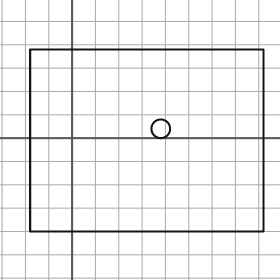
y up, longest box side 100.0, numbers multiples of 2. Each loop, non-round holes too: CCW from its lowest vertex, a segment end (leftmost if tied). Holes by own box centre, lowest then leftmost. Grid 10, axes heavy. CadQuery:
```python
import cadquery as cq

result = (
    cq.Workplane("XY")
    .moveTo(-18.0, -40.0)
    .lineTo(82.0, -40.0)
    .lineTo(82.0, 38.0)
    .lineTo(-18.0, 38.0)
    .close()
    .moveTo(38.0, 4.0)
    .circle(4.0)
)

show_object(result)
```